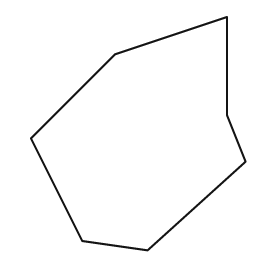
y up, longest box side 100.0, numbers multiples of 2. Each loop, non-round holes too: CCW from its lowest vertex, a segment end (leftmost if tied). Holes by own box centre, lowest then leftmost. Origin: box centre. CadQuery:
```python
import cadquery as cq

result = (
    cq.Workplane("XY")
    .moveTo(4.0, -50.0)
    .lineTo(46.0, -12.0)
    .lineTo(38.0, 8.0)
    .lineTo(38.0, 50.0)
    .lineTo(-10.0, 34.0)
    .lineTo(-46.0, -2.0)
    .lineTo(-24.0, -46.0)
    .close()
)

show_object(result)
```